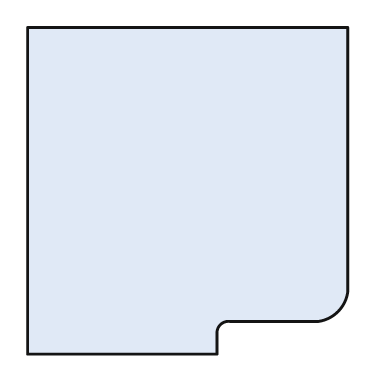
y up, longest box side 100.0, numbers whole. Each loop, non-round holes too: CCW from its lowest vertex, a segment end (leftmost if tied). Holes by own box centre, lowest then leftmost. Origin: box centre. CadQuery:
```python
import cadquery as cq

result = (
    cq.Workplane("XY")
    .moveTo(-49.0, -50.0)
    .lineTo(9.0, -50.0)
    .lineTo(9.0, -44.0)
    .threePointArc((10.0, -41.0), (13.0, -40.0))
    .lineTo(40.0, -40.0)
    .threePointArc((46.0, -37.0), (49.0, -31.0))
    .lineTo(49.0, 50.0)
    .lineTo(-49.0, 50.0)
    .close()
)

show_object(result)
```